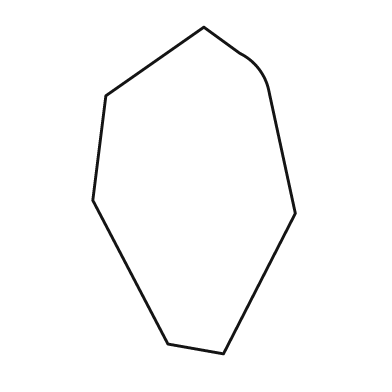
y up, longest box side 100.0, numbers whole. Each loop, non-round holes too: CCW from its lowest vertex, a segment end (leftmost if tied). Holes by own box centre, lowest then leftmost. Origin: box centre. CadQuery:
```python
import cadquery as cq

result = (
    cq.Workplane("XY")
    .moveTo(9.0, -50.0)
    .lineTo(31.0, -7.0)
    .lineTo(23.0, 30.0)
    .threePointArc((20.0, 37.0), (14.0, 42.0))
    .lineTo(3.0, 50.0)
    .lineTo(-27.0, 29.0)
    .lineTo(-31.0, -3.0)
    .lineTo(-8.0, -47.0)
    .close()
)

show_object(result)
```